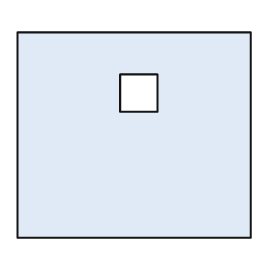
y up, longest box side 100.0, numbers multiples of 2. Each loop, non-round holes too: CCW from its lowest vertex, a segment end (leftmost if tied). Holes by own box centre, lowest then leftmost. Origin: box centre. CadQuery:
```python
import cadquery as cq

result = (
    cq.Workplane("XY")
    .moveTo(-50.0, -44.0)
    .lineTo(50.0, -44.0)
    .lineTo(50.0, 44.0)
    .lineTo(-50.0, 44.0)
    .close()
    .moveTo(-6.0, 10.0)
    .lineTo(10.0, 10.0)
    .lineTo(10.0, 26.0)
    .lineTo(-6.0, 26.0)
    .close()
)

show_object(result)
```